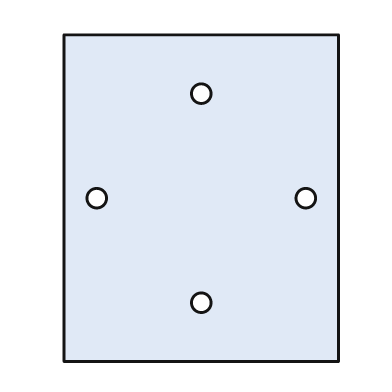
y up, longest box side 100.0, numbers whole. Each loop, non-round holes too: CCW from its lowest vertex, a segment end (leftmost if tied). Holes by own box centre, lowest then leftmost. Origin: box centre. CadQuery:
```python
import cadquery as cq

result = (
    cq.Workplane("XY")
    .moveTo(-42.0, -50.0)
    .lineTo(42.0, -50.0)
    .lineTo(42.0, 50.0)
    .lineTo(-42.0, 50.0)
    .close()
    .moveTo(0.0, -32.0)
    .circle(3.0)
    .moveTo(-32.0, 0.0)
    .circle(3.0)
    .moveTo(32.0, 0.0)
    .circle(3.0)
    .moveTo(0.0, 32.0)
    .circle(3.0)
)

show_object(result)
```